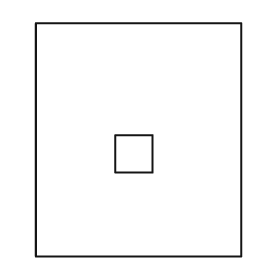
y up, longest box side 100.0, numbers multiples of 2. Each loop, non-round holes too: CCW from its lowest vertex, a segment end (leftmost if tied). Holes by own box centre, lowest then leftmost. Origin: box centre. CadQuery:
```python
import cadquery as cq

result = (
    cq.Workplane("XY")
    .moveTo(-44.0, -50.0)
    .lineTo(44.0, -50.0)
    .lineTo(44.0, 50.0)
    .lineTo(-44.0, 50.0)
    .close()
    .moveTo(-10.0, -14.0)
    .lineTo(6.0, -14.0)
    .lineTo(6.0, 2.0)
    .lineTo(-10.0, 2.0)
    .close()
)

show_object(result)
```